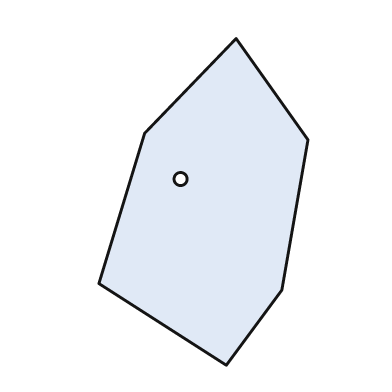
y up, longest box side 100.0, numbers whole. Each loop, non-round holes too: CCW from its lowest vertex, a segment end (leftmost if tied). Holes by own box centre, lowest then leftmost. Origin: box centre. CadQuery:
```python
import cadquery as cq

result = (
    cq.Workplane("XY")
    .moveTo(7.0, -50.0)
    .lineTo(24.0, -27.0)
    .lineTo(32.0, 19.0)
    .lineTo(10.0, 50.0)
    .lineTo(-18.0, 21.0)
    .lineTo(-32.0, -25.0)
    .close()
    .moveTo(-7.0, 7.0)
    .circle(2.0)
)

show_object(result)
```